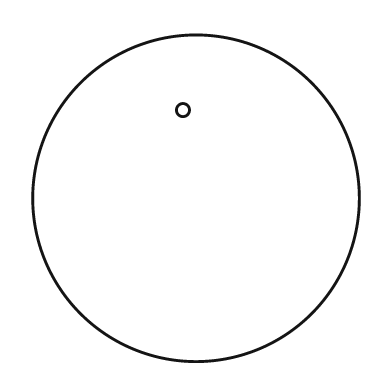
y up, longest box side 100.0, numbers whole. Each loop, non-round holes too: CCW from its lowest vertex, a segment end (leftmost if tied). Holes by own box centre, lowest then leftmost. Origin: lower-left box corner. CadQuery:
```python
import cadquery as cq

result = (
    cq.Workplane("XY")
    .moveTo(50.0, 50.0)
    .circle(50.0)
    .moveTo(46.0, 77.0)
    .circle(2.0)
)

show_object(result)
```